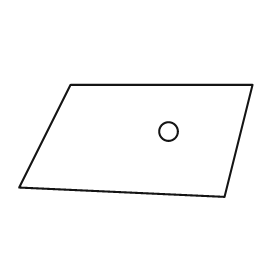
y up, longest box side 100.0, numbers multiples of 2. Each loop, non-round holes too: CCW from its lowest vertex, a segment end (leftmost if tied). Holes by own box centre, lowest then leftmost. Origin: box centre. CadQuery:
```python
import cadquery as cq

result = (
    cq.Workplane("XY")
    .moveTo(38.0, -24.0)
    .lineTo(50.0, 24.0)
    .lineTo(-28.0, 24.0)
    .lineTo(-50.0, -20.0)
    .close()
    .moveTo(14.0, 4.0)
    .circle(4.0)
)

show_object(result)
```